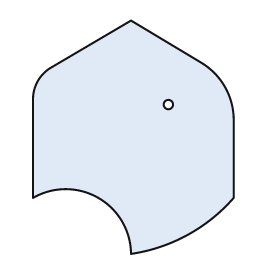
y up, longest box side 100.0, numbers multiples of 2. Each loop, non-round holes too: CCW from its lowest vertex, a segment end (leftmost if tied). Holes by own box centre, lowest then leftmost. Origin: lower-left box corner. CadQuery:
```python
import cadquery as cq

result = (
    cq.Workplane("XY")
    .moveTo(42.0, 0.0)
    .threePointArc((66.0, 8.0), (86.0, 24.0))
    .lineTo(86.0, 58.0)
    .threePointArc((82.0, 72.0), (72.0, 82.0))
    .lineTo(42.0, 100.0)
    .lineTo(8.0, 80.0)
    .threePointArc((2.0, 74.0), (0.0, 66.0))
    .lineTo(0.0, 24.0)
    .threePointArc((28.0, 24.0), (42.0, 0.0))
    .close()
    .moveTo(58.0, 64.0)
    .circle(2.0)
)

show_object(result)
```